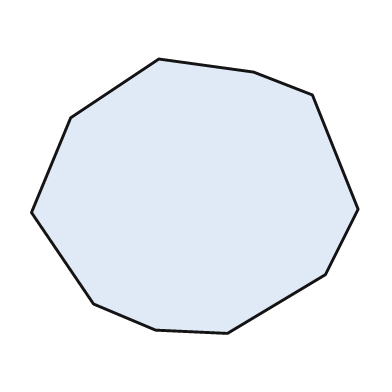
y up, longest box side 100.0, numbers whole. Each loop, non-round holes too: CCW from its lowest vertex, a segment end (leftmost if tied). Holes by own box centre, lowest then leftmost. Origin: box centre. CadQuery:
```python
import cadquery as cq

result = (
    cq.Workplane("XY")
    .moveTo(10.0, -42.0)
    .lineTo(40.0, -24.0)
    .lineTo(50.0, -4.0)
    .lineTo(36.0, 31.0)
    .lineTo(18.0, 38.0)
    .lineTo(-11.0, 42.0)
    .lineTo(-38.0, 24.0)
    .lineTo(-50.0, -5.0)
    .lineTo(-31.0, -33.0)
    .lineTo(-12.0, -41.0)
    .close()
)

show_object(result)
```